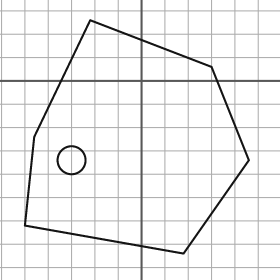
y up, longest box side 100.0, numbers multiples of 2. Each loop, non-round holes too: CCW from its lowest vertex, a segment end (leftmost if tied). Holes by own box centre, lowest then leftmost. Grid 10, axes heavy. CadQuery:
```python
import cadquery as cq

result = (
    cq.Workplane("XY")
    .moveTo(18.0, -74.0)
    .lineTo(46.0, -34.0)
    .lineTo(30.0, 6.0)
    .lineTo(-22.0, 26.0)
    .lineTo(-46.0, -24.0)
    .lineTo(-50.0, -62.0)
    .close()
    .moveTo(-30.0, -34.0)
    .circle(6.0)
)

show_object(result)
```